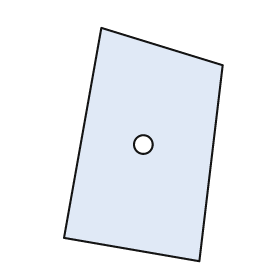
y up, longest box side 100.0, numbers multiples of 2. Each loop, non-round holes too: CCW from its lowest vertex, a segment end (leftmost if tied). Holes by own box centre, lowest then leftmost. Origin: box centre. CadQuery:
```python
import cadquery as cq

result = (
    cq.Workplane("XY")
    .moveTo(24.0, -50.0)
    .lineTo(34.0, 34.0)
    .lineTo(-18.0, 50.0)
    .lineTo(-34.0, -40.0)
    .close()
    .moveTo(0.0, 0.0)
    .circle(4.0)
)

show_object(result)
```